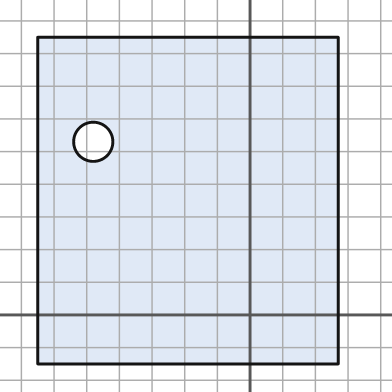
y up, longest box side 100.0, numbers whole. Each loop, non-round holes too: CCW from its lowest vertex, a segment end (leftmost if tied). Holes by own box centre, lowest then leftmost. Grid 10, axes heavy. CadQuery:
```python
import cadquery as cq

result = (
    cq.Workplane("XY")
    .moveTo(-65.0, -15.0)
    .lineTo(27.0, -15.0)
    .lineTo(27.0, 85.0)
    .lineTo(-65.0, 85.0)
    .close()
    .moveTo(-48.0, 53.0)
    .circle(6.0)
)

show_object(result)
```